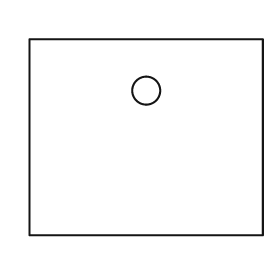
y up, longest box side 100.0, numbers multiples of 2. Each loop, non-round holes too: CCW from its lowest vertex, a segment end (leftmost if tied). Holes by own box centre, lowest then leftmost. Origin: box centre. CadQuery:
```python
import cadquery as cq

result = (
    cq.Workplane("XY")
    .moveTo(-50.0, -42.0)
    .lineTo(50.0, -42.0)
    .lineTo(50.0, 42.0)
    .lineTo(-50.0, 42.0)
    .close()
    .moveTo(0.0, 20.0)
    .circle(6.0)
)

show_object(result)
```